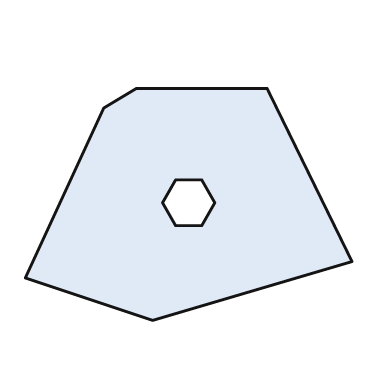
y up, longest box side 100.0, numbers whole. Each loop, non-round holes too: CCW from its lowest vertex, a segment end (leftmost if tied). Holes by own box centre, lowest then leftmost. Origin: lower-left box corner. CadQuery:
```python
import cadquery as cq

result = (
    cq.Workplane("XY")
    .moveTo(39.0, 0.0)
    .lineTo(100.0, 18.0)
    .lineTo(74.0, 71.0)
    .lineTo(34.0, 71.0)
    .lineTo(24.0, 65.0)
    .lineTo(0.0, 13.0)
    .close()
    .moveTo(46.0, 29.0)
    .lineTo(54.0, 29.0)
    .lineTo(58.0, 36.0)
    .lineTo(54.0, 43.0)
    .lineTo(46.0, 43.0)
    .lineTo(42.0, 36.0)
    .close()
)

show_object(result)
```